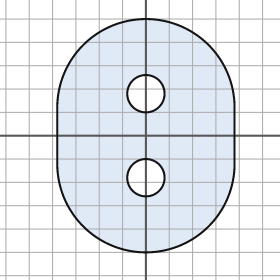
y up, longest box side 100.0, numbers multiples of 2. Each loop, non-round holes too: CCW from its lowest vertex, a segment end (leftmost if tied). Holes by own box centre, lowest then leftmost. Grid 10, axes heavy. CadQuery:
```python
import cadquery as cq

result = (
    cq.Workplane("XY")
    .moveTo(-38.0, -12.0)
    .threePointArc((0.0, -50.0), (38.0, -12.0))
    .lineTo(38.0, 12.0)
    .threePointArc((0.0, 50.0), (-38.0, 12.0))
    .close()
    .moveTo(0.0, -18.0)
    .circle(8.0)
    .moveTo(0.0, 18.0)
    .circle(8.0)
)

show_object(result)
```